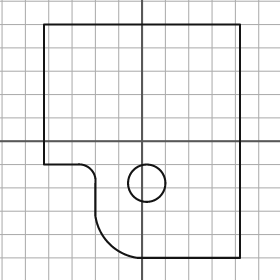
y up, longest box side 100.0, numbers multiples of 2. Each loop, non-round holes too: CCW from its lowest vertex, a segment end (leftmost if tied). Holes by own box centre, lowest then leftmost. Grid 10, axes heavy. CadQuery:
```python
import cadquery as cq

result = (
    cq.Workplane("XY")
    .moveTo(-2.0, -50.0)
    .lineTo(42.0, -50.0)
    .lineTo(42.0, 50.0)
    .lineTo(-42.0, 50.0)
    .lineTo(-42.0, -10.0)
    .lineTo(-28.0, -10.0)
    .threePointArc((-22.0, -12.0), (-20.0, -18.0))
    .lineTo(-20.0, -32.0)
    .threePointArc((-14.0, -44.0), (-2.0, -50.0))
    .close()
    .moveTo(2.0, -18.0)
    .circle(8.0)
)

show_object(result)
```